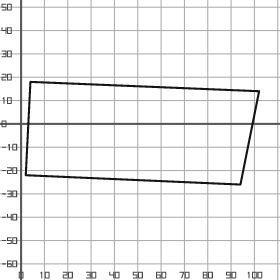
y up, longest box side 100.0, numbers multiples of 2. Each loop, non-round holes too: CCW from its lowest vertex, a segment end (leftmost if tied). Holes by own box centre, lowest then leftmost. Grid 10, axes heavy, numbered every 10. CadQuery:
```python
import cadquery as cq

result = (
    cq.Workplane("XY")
    .moveTo(94.0, -26.0)
    .lineTo(102.0, 14.0)
    .lineTo(4.0, 18.0)
    .lineTo(2.0, -22.0)
    .close()
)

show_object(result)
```